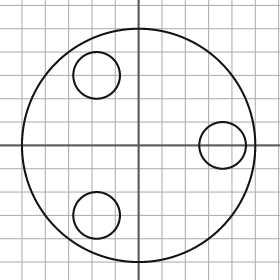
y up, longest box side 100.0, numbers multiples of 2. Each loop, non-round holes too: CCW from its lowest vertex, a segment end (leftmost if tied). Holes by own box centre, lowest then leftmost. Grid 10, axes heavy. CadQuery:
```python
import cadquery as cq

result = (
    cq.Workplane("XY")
    .moveTo(0.0, 0.0)
    .circle(50.0)
    .moveTo(-18.0, -30.0)
    .circle(10.0)
    .moveTo(36.0, 0.0)
    .circle(10.0)
    .moveTo(-18.0, 30.0)
    .circle(10.0)
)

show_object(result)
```